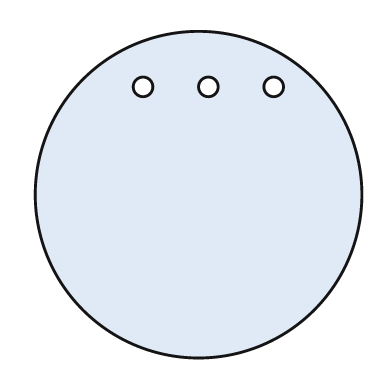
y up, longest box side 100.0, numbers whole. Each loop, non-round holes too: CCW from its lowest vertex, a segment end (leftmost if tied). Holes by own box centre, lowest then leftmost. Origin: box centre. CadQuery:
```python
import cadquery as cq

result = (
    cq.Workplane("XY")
    .moveTo(0.0, 0.0)
    .circle(50.0)
    .moveTo(-17.0, 33.0)
    .circle(3.0)
    .moveTo(3.0, 33.0)
    .circle(3.0)
    .moveTo(23.0, 33.0)
    .circle(3.0)
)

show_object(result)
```